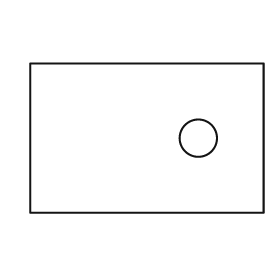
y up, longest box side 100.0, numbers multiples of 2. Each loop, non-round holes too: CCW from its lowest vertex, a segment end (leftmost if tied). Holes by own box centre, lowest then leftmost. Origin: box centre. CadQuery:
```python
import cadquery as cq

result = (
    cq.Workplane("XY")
    .moveTo(-50.0, -32.0)
    .lineTo(50.0, -32.0)
    .lineTo(50.0, 32.0)
    .lineTo(-50.0, 32.0)
    .close()
    .moveTo(22.0, 0.0)
    .circle(8.0)
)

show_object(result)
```